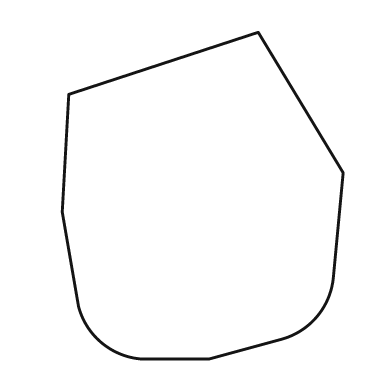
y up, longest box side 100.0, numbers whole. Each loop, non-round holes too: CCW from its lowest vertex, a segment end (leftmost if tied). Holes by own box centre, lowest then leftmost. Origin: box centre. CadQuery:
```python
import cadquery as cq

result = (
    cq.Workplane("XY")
    .moveTo(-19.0, -50.0)
    .lineTo(2.0, -50.0)
    .lineTo(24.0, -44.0)
    .threePointArc((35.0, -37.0), (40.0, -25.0))
    .lineTo(43.0, 7.0)
    .lineTo(17.0, 50.0)
    .lineTo(-41.0, 31.0)
    .lineTo(-43.0, -5.0)
    .lineTo(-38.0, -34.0)
    .threePointArc((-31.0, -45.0), (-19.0, -50.0))
    .close()
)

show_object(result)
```